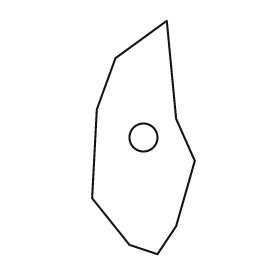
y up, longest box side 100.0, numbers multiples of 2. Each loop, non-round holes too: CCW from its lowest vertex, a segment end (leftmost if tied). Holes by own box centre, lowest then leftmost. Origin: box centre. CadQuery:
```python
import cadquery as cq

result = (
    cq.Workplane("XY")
    .moveTo(6.0, -50.0)
    .lineTo(14.0, -38.0)
    .lineTo(22.0, -10.0)
    .lineTo(14.0, 8.0)
    .lineTo(10.0, 50.0)
    .lineTo(-12.0, 34.0)
    .lineTo(-20.0, 12.0)
    .lineTo(-22.0, -26.0)
    .lineTo(-6.0, -46.0)
    .close()
    .moveTo(0.0, 0.0)
    .circle(6.0)
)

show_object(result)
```